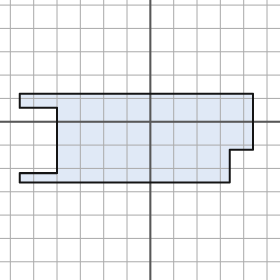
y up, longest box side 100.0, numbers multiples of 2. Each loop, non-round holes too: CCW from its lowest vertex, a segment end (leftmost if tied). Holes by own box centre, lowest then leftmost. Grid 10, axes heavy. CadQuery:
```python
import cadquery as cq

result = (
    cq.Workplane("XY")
    .moveTo(-56.0, -26.0)
    .lineTo(34.0, -26.0)
    .lineTo(34.0, -12.0)
    .lineTo(44.0, -12.0)
    .lineTo(44.0, 12.0)
    .lineTo(-56.0, 12.0)
    .lineTo(-56.0, 6.0)
    .lineTo(-40.0, 6.0)
    .lineTo(-40.0, -22.0)
    .lineTo(-56.0, -22.0)
    .close()
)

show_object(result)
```